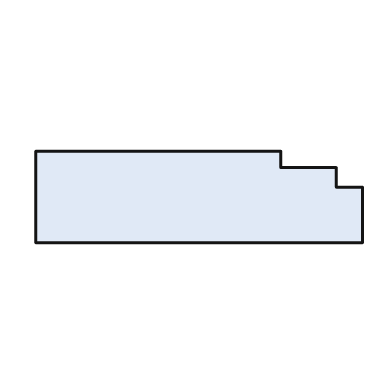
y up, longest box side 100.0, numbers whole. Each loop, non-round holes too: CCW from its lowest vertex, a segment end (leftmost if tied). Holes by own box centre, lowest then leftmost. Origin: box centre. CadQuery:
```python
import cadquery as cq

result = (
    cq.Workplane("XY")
    .moveTo(-50.0, -14.0)
    .lineTo(50.0, -14.0)
    .lineTo(50.0, 3.0)
    .lineTo(42.0, 3.0)
    .lineTo(42.0, 9.0)
    .lineTo(25.0, 9.0)
    .lineTo(25.0, 14.0)
    .lineTo(-50.0, 14.0)
    .close()
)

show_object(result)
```